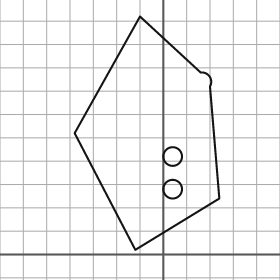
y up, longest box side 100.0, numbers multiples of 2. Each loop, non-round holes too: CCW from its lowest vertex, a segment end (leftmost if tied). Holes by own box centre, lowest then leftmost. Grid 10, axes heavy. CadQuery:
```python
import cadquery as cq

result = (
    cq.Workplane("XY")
    .moveTo(-12.0, 2.0)
    .lineTo(24.0, 24.0)
    .lineTo(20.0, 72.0)
    .threePointArc((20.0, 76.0), (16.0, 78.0))
    .lineTo(-10.0, 102.0)
    .lineTo(-38.0, 52.0)
    .close()
    .moveTo(4.0, 28.0)
    .circle(4.0)
    .moveTo(4.0, 42.0)
    .circle(4.0)
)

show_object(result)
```